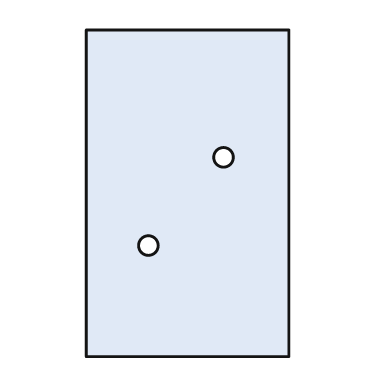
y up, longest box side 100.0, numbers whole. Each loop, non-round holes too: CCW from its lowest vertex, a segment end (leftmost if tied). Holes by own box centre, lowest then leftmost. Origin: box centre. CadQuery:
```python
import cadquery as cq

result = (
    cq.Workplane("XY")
    .moveTo(-31.0, -50.0)
    .lineTo(31.0, -50.0)
    .lineTo(31.0, 50.0)
    .lineTo(-31.0, 50.0)
    .close()
    .moveTo(-12.0, -16.0)
    .circle(3.0)
    .moveTo(11.0, 11.0)
    .circle(3.0)
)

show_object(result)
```